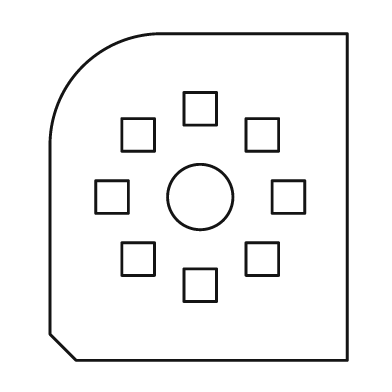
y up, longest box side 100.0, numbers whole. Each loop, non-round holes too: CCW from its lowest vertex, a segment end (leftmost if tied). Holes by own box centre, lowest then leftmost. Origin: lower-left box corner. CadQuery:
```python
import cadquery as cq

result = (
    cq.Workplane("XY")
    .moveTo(8.0, 0.0)
    .lineTo(91.0, 0.0)
    .lineTo(91.0, 100.0)
    .lineTo(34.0, 100.0)
    .threePointArc((10.0, 90.0), (0.0, 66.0))
    .lineTo(0.0, 8.0)
    .close()
    .moveTo(41.0, 18.0)
    .lineTo(51.0, 18.0)
    .lineTo(51.0, 28.0)
    .lineTo(41.0, 28.0)
    .close()
    .moveTo(22.0, 26.0)
    .lineTo(32.0, 26.0)
    .lineTo(32.0, 36.0)
    .lineTo(22.0, 36.0)
    .close()
    .moveTo(60.0, 26.0)
    .lineTo(70.0, 26.0)
    .lineTo(70.0, 36.0)
    .lineTo(60.0, 36.0)
    .close()
    .moveTo(14.0, 45.0)
    .lineTo(24.0, 45.0)
    .lineTo(24.0, 55.0)
    .lineTo(14.0, 55.0)
    .close()
    .moveTo(46.0, 50.0)
    .circle(10.0)
    .moveTo(68.0, 45.0)
    .lineTo(78.0, 45.0)
    .lineTo(78.0, 55.0)
    .lineTo(68.0, 55.0)
    .close()
    .moveTo(22.0, 64.0)
    .lineTo(32.0, 64.0)
    .lineTo(32.0, 74.0)
    .lineTo(22.0, 74.0)
    .close()
    .moveTo(60.0, 64.0)
    .lineTo(70.0, 64.0)
    .lineTo(70.0, 74.0)
    .lineTo(60.0, 74.0)
    .close()
    .moveTo(41.0, 72.0)
    .lineTo(51.0, 72.0)
    .lineTo(51.0, 82.0)
    .lineTo(41.0, 82.0)
    .close()
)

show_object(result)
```